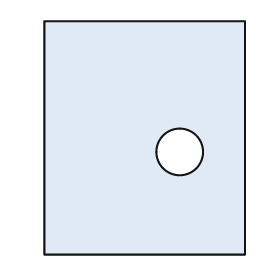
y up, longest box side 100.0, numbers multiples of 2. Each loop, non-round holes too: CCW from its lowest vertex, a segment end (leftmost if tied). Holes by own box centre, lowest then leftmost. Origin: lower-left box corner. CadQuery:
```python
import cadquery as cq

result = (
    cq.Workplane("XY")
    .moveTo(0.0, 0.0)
    .lineTo(86.0, 0.0)
    .lineTo(86.0, 100.0)
    .lineTo(0.0, 100.0)
    .close()
    .moveTo(58.0, 44.0)
    .circle(10.0)
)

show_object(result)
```